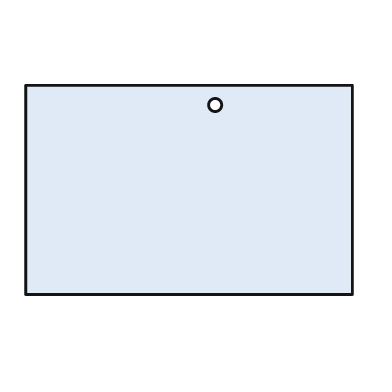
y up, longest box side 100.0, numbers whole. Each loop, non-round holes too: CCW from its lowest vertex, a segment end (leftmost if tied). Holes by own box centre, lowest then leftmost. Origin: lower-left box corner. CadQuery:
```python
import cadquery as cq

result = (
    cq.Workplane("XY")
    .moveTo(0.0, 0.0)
    .lineTo(100.0, 0.0)
    .lineTo(100.0, 64.0)
    .lineTo(0.0, 64.0)
    .close()
    .moveTo(58.0, 58.0)
    .circle(2.0)
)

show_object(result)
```